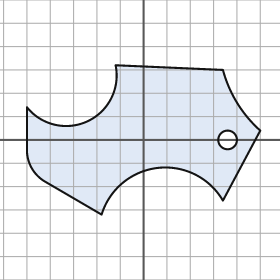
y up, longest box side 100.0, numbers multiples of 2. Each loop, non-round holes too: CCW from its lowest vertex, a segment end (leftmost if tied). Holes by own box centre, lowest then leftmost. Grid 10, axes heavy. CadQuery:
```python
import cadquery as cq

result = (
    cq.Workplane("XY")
    .moveTo(-18.0, -32.0)
    .threePointArc((6.0, -12.0), (34.0, -26.0))
    .lineTo(50.0, 4.0)
    .threePointArc((40.0, 16.0), (34.0, 30.0))
    .lineTo(-12.0, 32.0)
    .threePointArc((-24.0, 8.0), (-50.0, 14.0))
    .lineTo(-50.0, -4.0)
    .threePointArc((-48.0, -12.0), (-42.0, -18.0))
    .close()
    .moveTo(36.0, 0.0)
    .circle(4.0)
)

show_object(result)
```